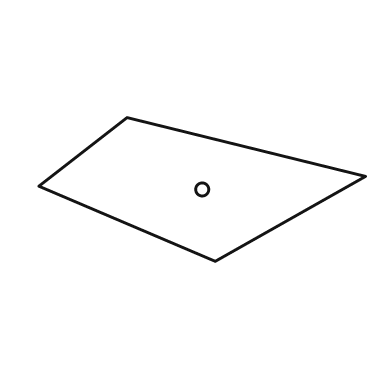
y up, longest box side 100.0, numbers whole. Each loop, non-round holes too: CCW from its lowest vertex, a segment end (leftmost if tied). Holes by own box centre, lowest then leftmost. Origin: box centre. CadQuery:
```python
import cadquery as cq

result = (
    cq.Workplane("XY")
    .moveTo(4.0, -22.0)
    .lineTo(50.0, 4.0)
    .lineTo(-23.0, 22.0)
    .lineTo(-50.0, 1.0)
    .close()
    .moveTo(0.0, 0.0)
    .circle(2.0)
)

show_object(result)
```